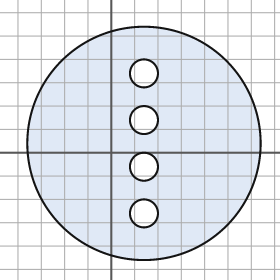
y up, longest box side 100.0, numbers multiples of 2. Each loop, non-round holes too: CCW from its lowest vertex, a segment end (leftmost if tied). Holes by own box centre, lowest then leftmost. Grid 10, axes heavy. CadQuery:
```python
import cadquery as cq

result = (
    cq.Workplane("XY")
    .moveTo(14.0, 4.0)
    .circle(50.0)
    .moveTo(14.0, -26.0)
    .circle(6.0)
    .moveTo(14.0, -6.0)
    .circle(6.0)
    .moveTo(14.0, 14.0)
    .circle(6.0)
    .moveTo(14.0, 34.0)
    .circle(6.0)
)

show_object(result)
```